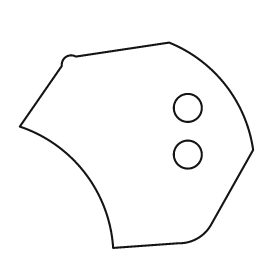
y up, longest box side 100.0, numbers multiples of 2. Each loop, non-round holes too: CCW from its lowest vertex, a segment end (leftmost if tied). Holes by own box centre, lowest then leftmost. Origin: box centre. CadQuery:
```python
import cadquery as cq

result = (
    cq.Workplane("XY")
    .moveTo(-10.0, -44.0)
    .lineTo(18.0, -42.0)
    .threePointArc((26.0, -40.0), (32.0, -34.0))
    .lineTo(50.0, -2.0)
    .threePointArc((38.0, 26.0), (14.0, 44.0))
    .lineTo(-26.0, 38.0)
    .threePointArc((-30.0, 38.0), (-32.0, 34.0))
    .lineTo(-50.0, 8.0)
    .threePointArc((-22.0, -12.0), (-10.0, -44.0))
    .close()
    .moveTo(22.0, -4.0)
    .circle(6.0)
    .moveTo(22.0, 16.0)
    .circle(6.0)
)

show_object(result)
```